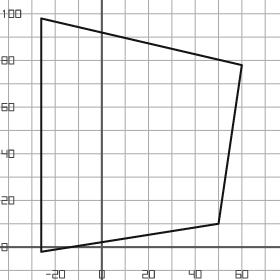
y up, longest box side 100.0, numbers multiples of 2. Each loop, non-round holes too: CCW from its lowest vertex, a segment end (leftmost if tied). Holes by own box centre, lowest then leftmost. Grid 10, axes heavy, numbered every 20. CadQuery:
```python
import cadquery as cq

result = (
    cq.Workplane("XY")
    .moveTo(-26.0, -2.0)
    .lineTo(50.0, 10.0)
    .lineTo(60.0, 78.0)
    .lineTo(-26.0, 98.0)
    .close()
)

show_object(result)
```